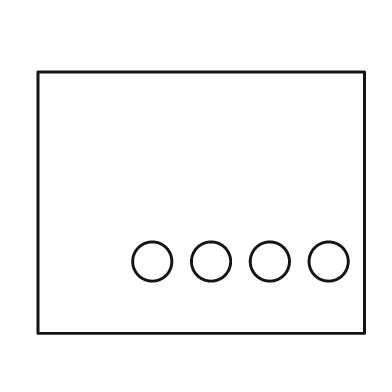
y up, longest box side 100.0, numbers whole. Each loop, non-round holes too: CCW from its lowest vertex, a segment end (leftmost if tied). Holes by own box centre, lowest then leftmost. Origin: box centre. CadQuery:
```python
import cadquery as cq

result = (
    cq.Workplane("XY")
    .moveTo(-50.0, -40.0)
    .lineTo(50.0, -40.0)
    .lineTo(50.0, 40.0)
    .lineTo(-50.0, 40.0)
    .close()
    .moveTo(-15.0, -18.0)
    .circle(6.0)
    .moveTo(3.0, -18.0)
    .circle(6.0)
    .moveTo(21.0, -18.0)
    .circle(6.0)
    .moveTo(39.0, -18.0)
    .circle(6.0)
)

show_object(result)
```